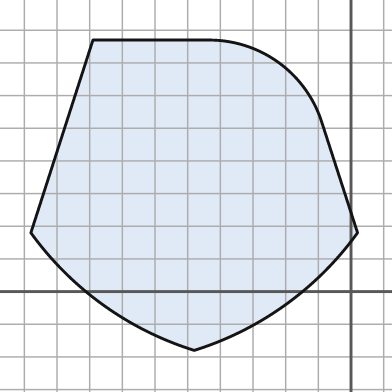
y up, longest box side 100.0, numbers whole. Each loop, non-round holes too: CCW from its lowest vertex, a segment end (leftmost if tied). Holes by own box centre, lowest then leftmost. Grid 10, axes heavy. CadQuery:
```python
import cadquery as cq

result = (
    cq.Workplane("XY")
    .moveTo(-48.0, -18.0)
    .threePointArc((-20.0, -4.0), (2.0, 18.0))
    .lineTo(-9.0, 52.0)
    .threePointArc((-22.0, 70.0), (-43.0, 77.0))
    .lineTo(-79.0, 77.0)
    .lineTo(-98.0, 18.0)
    .threePointArc((-76.0, -4.0), (-48.0, -18.0))
    .close()
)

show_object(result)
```